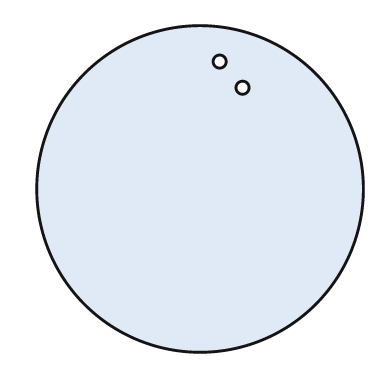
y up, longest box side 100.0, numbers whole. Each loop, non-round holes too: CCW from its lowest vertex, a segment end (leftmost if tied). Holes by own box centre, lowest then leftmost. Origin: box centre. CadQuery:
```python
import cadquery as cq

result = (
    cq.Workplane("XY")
    .moveTo(0.0, 0.0)
    .circle(50.0)
    .moveTo(13.0, 31.0)
    .circle(2.0)
    .moveTo(6.0, 39.0)
    .circle(2.0)
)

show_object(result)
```